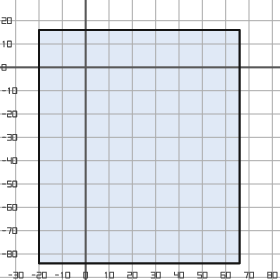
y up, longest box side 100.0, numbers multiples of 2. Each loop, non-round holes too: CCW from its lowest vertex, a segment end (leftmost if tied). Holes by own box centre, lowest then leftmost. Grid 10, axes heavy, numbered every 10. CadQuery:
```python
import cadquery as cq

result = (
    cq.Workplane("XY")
    .moveTo(-20.0, -84.0)
    .lineTo(66.0, -84.0)
    .lineTo(66.0, 16.0)
    .lineTo(-20.0, 16.0)
    .close()
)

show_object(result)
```